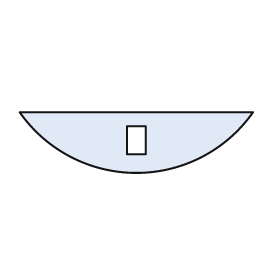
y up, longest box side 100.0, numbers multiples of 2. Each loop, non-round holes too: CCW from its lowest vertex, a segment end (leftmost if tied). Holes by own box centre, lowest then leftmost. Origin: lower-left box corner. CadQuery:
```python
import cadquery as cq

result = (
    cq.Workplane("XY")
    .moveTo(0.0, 26.0)
    .threePointArc((50.0, 0.0), (100.0, 26.0))
    .close()
    .moveTo(46.0, 8.0)
    .lineTo(54.0, 8.0)
    .lineTo(54.0, 20.0)
    .lineTo(46.0, 20.0)
    .close()
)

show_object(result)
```